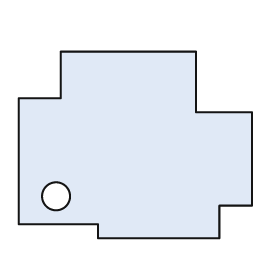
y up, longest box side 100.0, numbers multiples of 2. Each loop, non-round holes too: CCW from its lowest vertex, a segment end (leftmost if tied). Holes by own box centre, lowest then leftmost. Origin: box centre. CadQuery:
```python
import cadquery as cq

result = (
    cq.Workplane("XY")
    .moveTo(-16.0, -40.0)
    .lineTo(36.0, -40.0)
    .lineTo(36.0, -26.0)
    .lineTo(50.0, -26.0)
    .lineTo(50.0, 14.0)
    .lineTo(26.0, 14.0)
    .lineTo(26.0, 40.0)
    .lineTo(-32.0, 40.0)
    .lineTo(-32.0, 20.0)
    .lineTo(-50.0, 20.0)
    .lineTo(-50.0, -34.0)
    .lineTo(-16.0, -34.0)
    .close()
    .moveTo(-34.0, -22.0)
    .circle(6.0)
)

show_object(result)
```